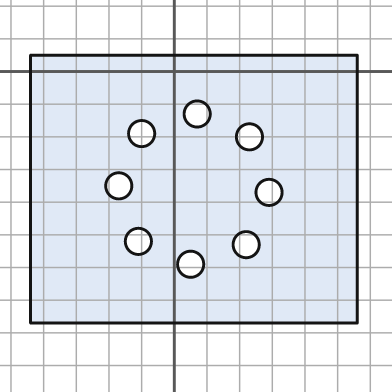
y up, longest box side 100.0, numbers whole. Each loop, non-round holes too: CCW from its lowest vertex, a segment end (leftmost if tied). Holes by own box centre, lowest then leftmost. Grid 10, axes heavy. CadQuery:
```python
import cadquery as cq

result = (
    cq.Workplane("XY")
    .moveTo(-44.0, -77.0)
    .lineTo(56.0, -77.0)
    .lineTo(56.0, 5.0)
    .lineTo(-44.0, 5.0)
    .close()
    .moveTo(5.0, -59.0)
    .circle(4.0)
    .moveTo(22.0, -53.0)
    .circle(4.0)
    .moveTo(-11.0, -52.0)
    .circle(4.0)
    .moveTo(29.0, -37.0)
    .circle(4.0)
    .moveTo(-17.0, -35.0)
    .circle(4.0)
    .moveTo(23.0, -20.0)
    .circle(4.0)
    .moveTo(-10.0, -19.0)
    .circle(4.0)
    .moveTo(7.0, -13.0)
    .circle(4.0)
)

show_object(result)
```